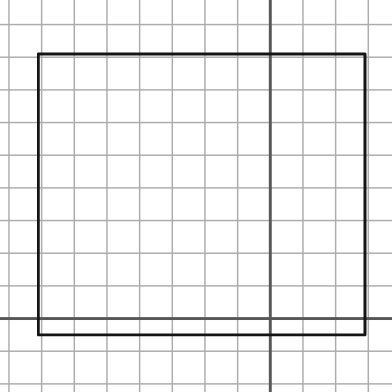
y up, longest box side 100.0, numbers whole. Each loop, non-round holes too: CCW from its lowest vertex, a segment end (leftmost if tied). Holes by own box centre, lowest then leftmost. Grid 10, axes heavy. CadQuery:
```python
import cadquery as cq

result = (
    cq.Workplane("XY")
    .moveTo(-71.0, -5.0)
    .lineTo(29.0, -5.0)
    .lineTo(29.0, 81.0)
    .lineTo(-71.0, 81.0)
    .close()
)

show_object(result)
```